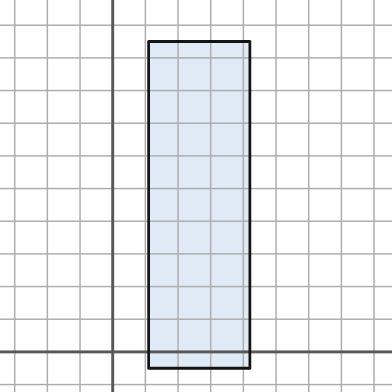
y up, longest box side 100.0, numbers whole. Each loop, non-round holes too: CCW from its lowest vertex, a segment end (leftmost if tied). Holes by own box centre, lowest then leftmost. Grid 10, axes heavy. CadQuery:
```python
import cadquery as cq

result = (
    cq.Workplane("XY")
    .moveTo(11.0, -5.0)
    .lineTo(42.0, -5.0)
    .lineTo(42.0, 95.0)
    .lineTo(11.0, 95.0)
    .close()
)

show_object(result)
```